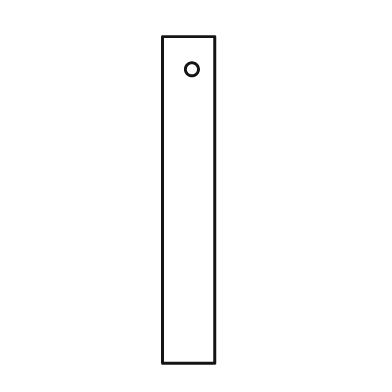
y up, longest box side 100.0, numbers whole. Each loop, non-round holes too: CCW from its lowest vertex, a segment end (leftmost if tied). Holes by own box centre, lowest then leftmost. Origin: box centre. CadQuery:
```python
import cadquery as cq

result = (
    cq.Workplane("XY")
    .moveTo(-8.0, -50.0)
    .lineTo(8.0, -50.0)
    .lineTo(8.0, 50.0)
    .lineTo(-8.0, 50.0)
    .close()
    .moveTo(1.0, 40.0)
    .circle(2.0)
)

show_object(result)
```